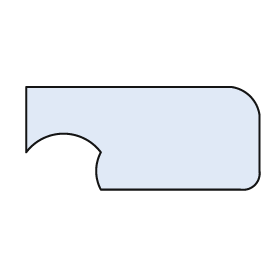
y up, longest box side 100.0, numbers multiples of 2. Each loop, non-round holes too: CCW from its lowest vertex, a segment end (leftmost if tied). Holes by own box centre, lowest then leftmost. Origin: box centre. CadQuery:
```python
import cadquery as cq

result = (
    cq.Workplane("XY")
    .moveTo(-18.0, -22.0)
    .lineTo(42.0, -22.0)
    .threePointArc((48.0, -20.0), (50.0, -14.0))
    .lineTo(50.0, 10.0)
    .threePointArc((46.0, 18.0), (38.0, 22.0))
    .lineTo(-50.0, 22.0)
    .lineTo(-50.0, -6.0)
    .threePointArc((-34.0, 2.0), (-18.0, -6.0))
    .threePointArc((-20.0, -14.0), (-18.0, -22.0))
    .close()
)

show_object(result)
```